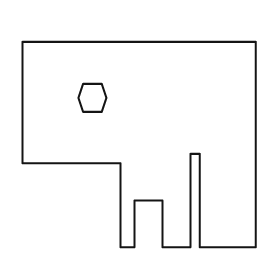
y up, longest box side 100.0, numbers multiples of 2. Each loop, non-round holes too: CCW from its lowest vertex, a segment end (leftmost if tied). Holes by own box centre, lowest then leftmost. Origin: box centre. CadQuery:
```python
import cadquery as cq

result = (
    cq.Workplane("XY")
    .moveTo(-8.0, -44.0)
    .lineTo(-2.0, -44.0)
    .lineTo(-2.0, -24.0)
    .lineTo(10.0, -24.0)
    .lineTo(10.0, -44.0)
    .lineTo(22.0, -44.0)
    .lineTo(22.0, -4.0)
    .lineTo(26.0, -4.0)
    .lineTo(26.0, -44.0)
    .lineTo(50.0, -44.0)
    .lineTo(50.0, 44.0)
    .lineTo(-50.0, 44.0)
    .lineTo(-50.0, -8.0)
    .lineTo(-8.0, -8.0)
    .close()
    .moveTo(-24.0, 14.0)
    .lineTo(-16.0, 14.0)
    .lineTo(-14.0, 20.0)
    .lineTo(-16.0, 26.0)
    .lineTo(-24.0, 26.0)
    .lineTo(-26.0, 20.0)
    .close()
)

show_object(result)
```